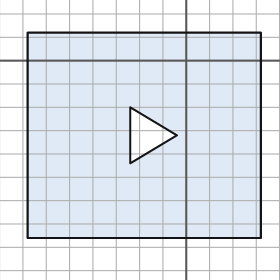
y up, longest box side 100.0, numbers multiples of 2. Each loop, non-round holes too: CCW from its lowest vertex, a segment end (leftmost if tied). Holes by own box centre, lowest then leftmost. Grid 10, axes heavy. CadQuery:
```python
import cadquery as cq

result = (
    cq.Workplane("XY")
    .moveTo(-68.0, -76.0)
    .lineTo(32.0, -76.0)
    .lineTo(32.0, 12.0)
    .lineTo(-68.0, 12.0)
    .close()
    .moveTo(-24.0, -44.0)
    .lineTo(-4.0, -32.0)
    .lineTo(-24.0, -20.0)
    .close()
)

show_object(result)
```